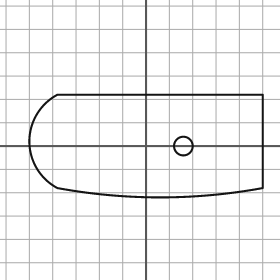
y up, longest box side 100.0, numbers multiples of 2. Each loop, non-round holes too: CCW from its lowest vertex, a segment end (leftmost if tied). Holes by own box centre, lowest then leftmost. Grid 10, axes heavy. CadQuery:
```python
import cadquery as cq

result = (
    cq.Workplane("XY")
    .moveTo(-38.0, -18.0)
    .threePointArc((6.0, -22.0), (50.0, -18.0))
    .lineTo(50.0, 22.0)
    .lineTo(-38.0, 22.0)
    .threePointArc((-50.0, 2.0), (-38.0, -18.0))
    .close()
    .moveTo(16.0, 0.0)
    .circle(4.0)
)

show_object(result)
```